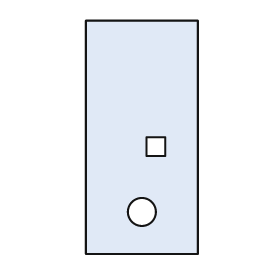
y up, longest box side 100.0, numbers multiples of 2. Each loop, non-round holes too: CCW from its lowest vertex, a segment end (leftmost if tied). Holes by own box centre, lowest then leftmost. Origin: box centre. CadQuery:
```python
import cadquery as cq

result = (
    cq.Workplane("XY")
    .moveTo(-24.0, -50.0)
    .lineTo(24.0, -50.0)
    .lineTo(24.0, 50.0)
    .lineTo(-24.0, 50.0)
    .close()
    .moveTo(0.0, -32.0)
    .circle(6.0)
    .moveTo(2.0, -8.0)
    .lineTo(10.0, -8.0)
    .lineTo(10.0, 0.0)
    .lineTo(2.0, 0.0)
    .close()
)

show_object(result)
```